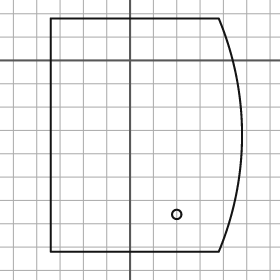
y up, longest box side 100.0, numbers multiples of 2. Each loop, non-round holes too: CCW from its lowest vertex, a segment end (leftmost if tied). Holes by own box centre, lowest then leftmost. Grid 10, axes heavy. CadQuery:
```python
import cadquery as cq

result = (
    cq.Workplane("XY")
    .moveTo(-34.0, -82.0)
    .lineTo(38.0, -82.0)
    .threePointArc((48.0, -32.0), (38.0, 18.0))
    .lineTo(-34.0, 18.0)
    .close()
    .moveTo(20.0, -66.0)
    .circle(2.0)
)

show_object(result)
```